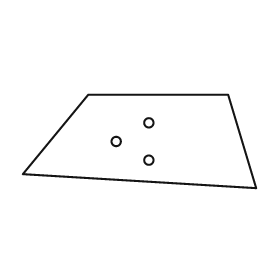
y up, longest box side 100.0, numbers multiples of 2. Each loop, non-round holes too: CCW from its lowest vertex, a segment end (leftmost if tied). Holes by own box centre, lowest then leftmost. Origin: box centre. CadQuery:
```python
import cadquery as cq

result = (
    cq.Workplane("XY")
    .moveTo(50.0, -20.0)
    .lineTo(38.0, 20.0)
    .lineTo(-22.0, 20.0)
    .lineTo(-50.0, -14.0)
    .close()
    .moveTo(4.0, -8.0)
    .circle(2.0)
    .moveTo(-10.0, 0.0)
    .circle(2.0)
    .moveTo(4.0, 8.0)
    .circle(2.0)
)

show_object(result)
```